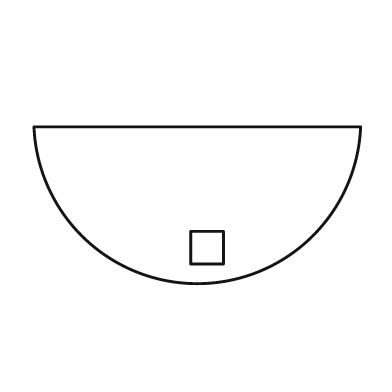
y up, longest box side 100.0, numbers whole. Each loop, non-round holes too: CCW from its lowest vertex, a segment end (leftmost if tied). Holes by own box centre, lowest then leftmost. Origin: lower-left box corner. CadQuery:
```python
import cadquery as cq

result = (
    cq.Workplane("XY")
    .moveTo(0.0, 48.0)
    .threePointArc((50.0, 0.0), (100.0, 48.0))
    .close()
    .moveTo(48.0, 6.0)
    .lineTo(58.0, 6.0)
    .lineTo(58.0, 16.0)
    .lineTo(48.0, 16.0)
    .close()
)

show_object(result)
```